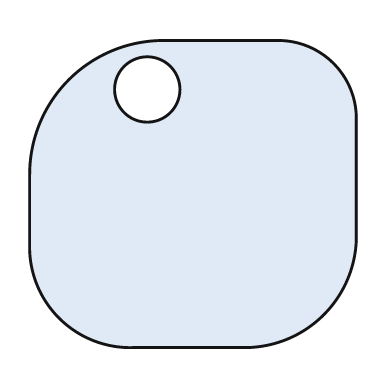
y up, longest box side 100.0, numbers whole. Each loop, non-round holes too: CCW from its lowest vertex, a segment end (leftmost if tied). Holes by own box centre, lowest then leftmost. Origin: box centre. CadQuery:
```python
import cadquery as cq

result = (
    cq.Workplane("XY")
    .moveTo(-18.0, -47.0)
    .lineTo(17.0, -47.0)
    .threePointArc((40.0, -37.0), (50.0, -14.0))
    .lineTo(50.0, 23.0)
    .threePointArc((43.0, 40.0), (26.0, 47.0))
    .lineTo(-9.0, 47.0)
    .threePointArc((-38.0, 35.0), (-50.0, 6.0))
    .lineTo(-50.0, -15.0)
    .threePointArc((-41.0, -38.0), (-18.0, -47.0))
    .close()
    .moveTo(-14.0, 32.0)
    .circle(10.0)
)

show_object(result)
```